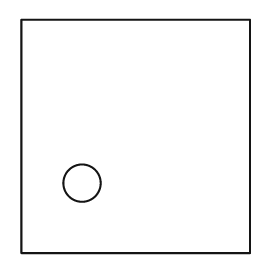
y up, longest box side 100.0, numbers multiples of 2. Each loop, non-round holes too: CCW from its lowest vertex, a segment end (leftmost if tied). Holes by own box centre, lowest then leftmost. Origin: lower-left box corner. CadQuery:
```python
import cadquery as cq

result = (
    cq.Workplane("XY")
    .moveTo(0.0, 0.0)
    .lineTo(98.0, 0.0)
    .lineTo(98.0, 100.0)
    .lineTo(0.0, 100.0)
    .close()
    .moveTo(26.0, 30.0)
    .circle(8.0)
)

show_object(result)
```